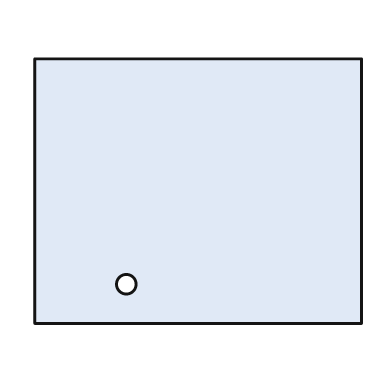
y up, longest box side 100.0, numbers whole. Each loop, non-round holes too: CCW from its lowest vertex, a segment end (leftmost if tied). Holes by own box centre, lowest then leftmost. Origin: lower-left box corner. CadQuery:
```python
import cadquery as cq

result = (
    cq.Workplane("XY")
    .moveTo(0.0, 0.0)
    .lineTo(100.0, 0.0)
    .lineTo(100.0, 81.0)
    .lineTo(0.0, 81.0)
    .close()
    .moveTo(28.0, 12.0)
    .circle(3.0)
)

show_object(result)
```